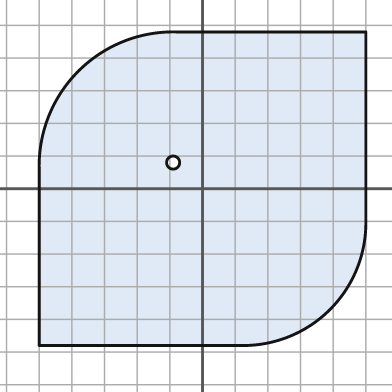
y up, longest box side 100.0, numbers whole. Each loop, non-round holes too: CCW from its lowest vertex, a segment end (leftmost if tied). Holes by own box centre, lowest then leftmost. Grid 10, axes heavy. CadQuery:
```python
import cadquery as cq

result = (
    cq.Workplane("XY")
    .moveTo(-50.0, -48.0)
    .lineTo(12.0, -48.0)
    .threePointArc((39.0, -37.0), (50.0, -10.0))
    .lineTo(50.0, 48.0)
    .lineTo(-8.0, 48.0)
    .threePointArc((-38.0, 36.0), (-50.0, 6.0))
    .close()
    .moveTo(-9.0, 8.0)
    .circle(2.0)
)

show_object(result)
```